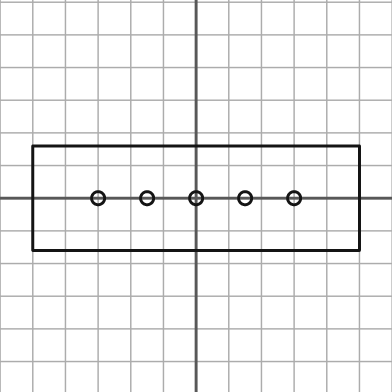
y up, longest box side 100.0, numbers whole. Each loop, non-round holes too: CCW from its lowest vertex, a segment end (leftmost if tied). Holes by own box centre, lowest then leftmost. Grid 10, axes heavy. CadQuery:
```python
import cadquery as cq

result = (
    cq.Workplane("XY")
    .moveTo(-50.0, -16.0)
    .lineTo(50.0, -16.0)
    .lineTo(50.0, 16.0)
    .lineTo(-50.0, 16.0)
    .close()
    .moveTo(-30.0, 0.0)
    .circle(2.0)
    .moveTo(-15.0, 0.0)
    .circle(2.0)
    .moveTo(0.0, 0.0)
    .circle(2.0)
    .moveTo(15.0, 0.0)
    .circle(2.0)
    .moveTo(30.0, 0.0)
    .circle(2.0)
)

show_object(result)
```